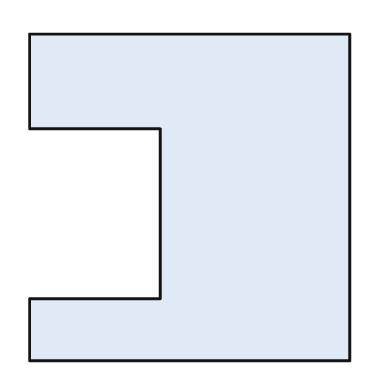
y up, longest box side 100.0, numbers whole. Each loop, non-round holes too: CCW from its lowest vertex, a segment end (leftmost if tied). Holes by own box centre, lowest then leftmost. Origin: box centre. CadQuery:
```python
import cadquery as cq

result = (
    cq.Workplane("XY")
    .moveTo(-49.0, -50.0)
    .lineTo(49.0, -50.0)
    .lineTo(49.0, 50.0)
    .lineTo(-49.0, 50.0)
    .lineTo(-49.0, 21.0)
    .lineTo(-9.0, 21.0)
    .lineTo(-9.0, -31.0)
    .lineTo(-49.0, -31.0)
    .close()
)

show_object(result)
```